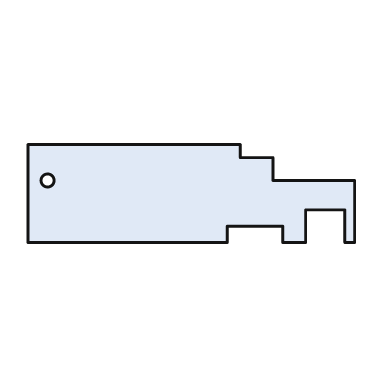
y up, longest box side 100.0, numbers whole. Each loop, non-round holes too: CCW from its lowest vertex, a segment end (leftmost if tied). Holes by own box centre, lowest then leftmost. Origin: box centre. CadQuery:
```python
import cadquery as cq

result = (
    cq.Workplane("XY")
    .moveTo(-50.0, -15.0)
    .lineTo(11.0, -15.0)
    .lineTo(11.0, -10.0)
    .lineTo(28.0, -10.0)
    .lineTo(28.0, -15.0)
    .lineTo(35.0, -15.0)
    .lineTo(35.0, -5.0)
    .lineTo(47.0, -5.0)
    .lineTo(47.0, -15.0)
    .lineTo(50.0, -15.0)
    .lineTo(50.0, 4.0)
    .lineTo(25.0, 4.0)
    .lineTo(25.0, 11.0)
    .lineTo(15.0, 11.0)
    .lineTo(15.0, 15.0)
    .lineTo(-50.0, 15.0)
    .close()
    .moveTo(-44.0, 4.0)
    .circle(2.0)
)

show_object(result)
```